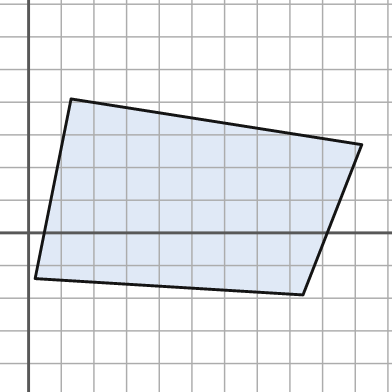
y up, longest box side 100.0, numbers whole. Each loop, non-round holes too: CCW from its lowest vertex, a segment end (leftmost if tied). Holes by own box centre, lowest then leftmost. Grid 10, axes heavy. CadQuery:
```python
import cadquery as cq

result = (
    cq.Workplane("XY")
    .moveTo(84.0, -19.0)
    .lineTo(102.0, 27.0)
    .lineTo(13.0, 41.0)
    .lineTo(2.0, -14.0)
    .close()
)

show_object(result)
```